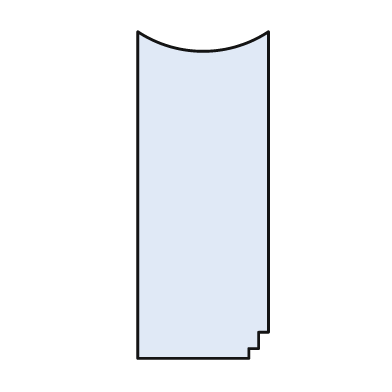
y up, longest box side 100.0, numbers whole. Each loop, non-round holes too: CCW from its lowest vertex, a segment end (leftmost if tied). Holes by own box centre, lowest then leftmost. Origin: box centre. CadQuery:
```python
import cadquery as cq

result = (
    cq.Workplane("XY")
    .moveTo(-20.0, -50.0)
    .lineTo(14.0, -50.0)
    .lineTo(14.0, -47.0)
    .lineTo(17.0, -47.0)
    .lineTo(17.0, -42.0)
    .lineTo(20.0, -42.0)
    .lineTo(20.0, 50.0)
    .threePointArc((0.0, 44.0), (-20.0, 50.0))
    .close()
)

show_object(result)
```